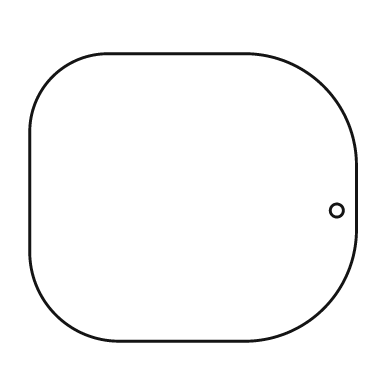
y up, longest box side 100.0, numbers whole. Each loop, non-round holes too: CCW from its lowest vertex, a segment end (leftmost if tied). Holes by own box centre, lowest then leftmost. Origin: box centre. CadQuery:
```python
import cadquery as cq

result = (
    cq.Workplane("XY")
    .moveTo(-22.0, -44.0)
    .lineTo(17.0, -44.0)
    .threePointArc((40.0, -34.0), (50.0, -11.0))
    .lineTo(50.0, 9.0)
    .threePointArc((40.0, 34.0), (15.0, 44.0))
    .lineTo(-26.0, 44.0)
    .threePointArc((-43.0, 37.0), (-50.0, 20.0))
    .lineTo(-50.0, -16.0)
    .threePointArc((-42.0, -36.0), (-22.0, -44.0))
    .close()
    .moveTo(44.0, -4.0)
    .circle(2.0)
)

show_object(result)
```